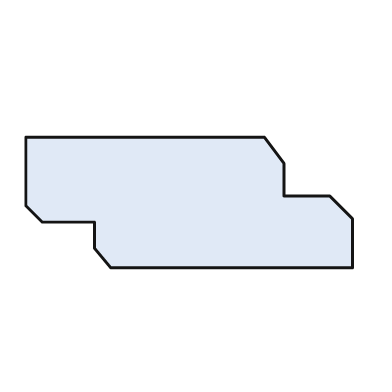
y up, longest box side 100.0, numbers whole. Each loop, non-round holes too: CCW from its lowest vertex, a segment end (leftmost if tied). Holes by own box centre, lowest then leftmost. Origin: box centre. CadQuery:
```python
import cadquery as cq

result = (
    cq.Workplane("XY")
    .moveTo(-24.0, -20.0)
    .lineTo(50.0, -20.0)
    .lineTo(50.0, -5.0)
    .lineTo(43.0, 2.0)
    .lineTo(29.0, 2.0)
    .lineTo(29.0, 12.0)
    .lineTo(23.0, 20.0)
    .lineTo(-50.0, 20.0)
    .lineTo(-50.0, -1.0)
    .lineTo(-45.0, -6.0)
    .lineTo(-29.0, -6.0)
    .lineTo(-29.0, -14.0)
    .close()
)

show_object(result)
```